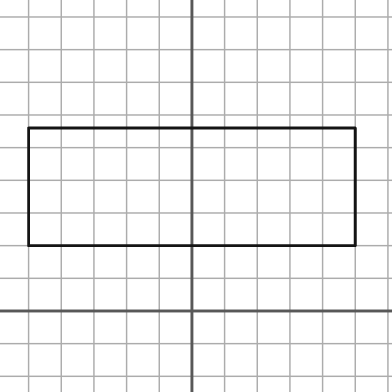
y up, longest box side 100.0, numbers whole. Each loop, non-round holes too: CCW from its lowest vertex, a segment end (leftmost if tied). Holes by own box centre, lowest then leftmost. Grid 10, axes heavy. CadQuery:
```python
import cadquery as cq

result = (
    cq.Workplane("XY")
    .moveTo(-50.0, 20.0)
    .lineTo(50.0, 20.0)
    .lineTo(50.0, 56.0)
    .lineTo(-50.0, 56.0)
    .close()
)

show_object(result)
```